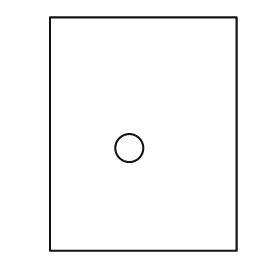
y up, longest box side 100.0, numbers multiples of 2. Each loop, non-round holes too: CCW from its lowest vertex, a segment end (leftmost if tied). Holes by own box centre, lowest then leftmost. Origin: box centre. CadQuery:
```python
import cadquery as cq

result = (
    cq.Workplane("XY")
    .moveTo(-40.0, -50.0)
    .lineTo(40.0, -50.0)
    .lineTo(40.0, 50.0)
    .lineTo(-40.0, 50.0)
    .close()
    .moveTo(-6.0, -6.0)
    .circle(6.0)
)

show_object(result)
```